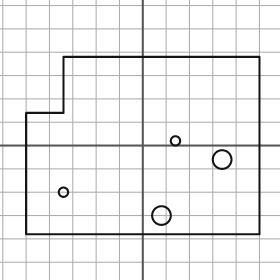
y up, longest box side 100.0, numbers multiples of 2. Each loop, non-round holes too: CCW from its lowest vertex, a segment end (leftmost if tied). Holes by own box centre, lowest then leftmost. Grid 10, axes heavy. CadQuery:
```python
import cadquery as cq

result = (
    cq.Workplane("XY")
    .moveTo(-50.0, -38.0)
    .lineTo(50.0, -38.0)
    .lineTo(50.0, 38.0)
    .lineTo(-34.0, 38.0)
    .lineTo(-34.0, 14.0)
    .lineTo(-50.0, 14.0)
    .close()
    .moveTo(8.0, -30.0)
    .circle(4.0)
    .moveTo(-34.0, -20.0)
    .circle(2.0)
    .moveTo(34.0, -6.0)
    .circle(4.0)
    .moveTo(14.0, 2.0)
    .circle(2.0)
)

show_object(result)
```